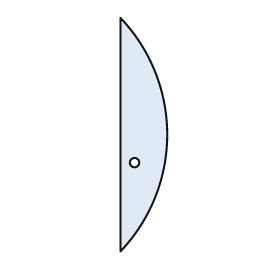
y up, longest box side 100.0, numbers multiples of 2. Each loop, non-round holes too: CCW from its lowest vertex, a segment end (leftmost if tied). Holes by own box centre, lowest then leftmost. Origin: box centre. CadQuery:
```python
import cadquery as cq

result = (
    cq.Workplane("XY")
    .moveTo(-10.0, -50.0)
    .threePointArc((10.0, 0.0), (-10.0, 50.0))
    .close()
    .moveTo(-4.0, -12.0)
    .circle(2.0)
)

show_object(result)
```